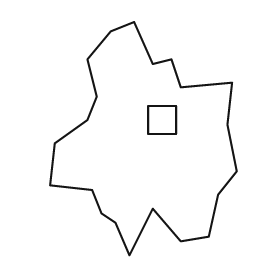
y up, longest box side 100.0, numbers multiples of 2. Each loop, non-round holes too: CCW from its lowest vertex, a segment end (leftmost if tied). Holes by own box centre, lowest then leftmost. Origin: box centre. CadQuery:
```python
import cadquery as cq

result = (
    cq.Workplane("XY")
    .moveTo(-6.0, -50.0)
    .lineTo(4.0, -30.0)
    .lineTo(16.0, -44.0)
    .lineTo(28.0, -42.0)
    .lineTo(32.0, -24.0)
    .lineTo(40.0, -14.0)
    .lineTo(36.0, 6.0)
    .lineTo(38.0, 24.0)
    .lineTo(16.0, 22.0)
    .lineTo(12.0, 34.0)
    .lineTo(4.0, 32.0)
    .lineTo(-4.0, 50.0)
    .lineTo(-14.0, 46.0)
    .lineTo(-24.0, 34.0)
    .lineTo(-20.0, 18.0)
    .lineTo(-24.0, 8.0)
    .lineTo(-38.0, -2.0)
    .lineTo(-40.0, -20.0)
    .lineTo(-22.0, -22.0)
    .lineTo(-18.0, -32.0)
    .lineTo(-12.0, -36.0)
    .close()
    .moveTo(2.0, 2.0)
    .lineTo(14.0, 2.0)
    .lineTo(14.0, 14.0)
    .lineTo(2.0, 14.0)
    .close()
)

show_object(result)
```